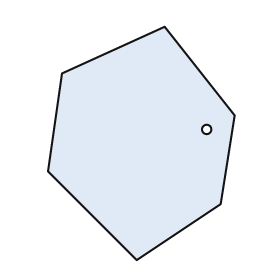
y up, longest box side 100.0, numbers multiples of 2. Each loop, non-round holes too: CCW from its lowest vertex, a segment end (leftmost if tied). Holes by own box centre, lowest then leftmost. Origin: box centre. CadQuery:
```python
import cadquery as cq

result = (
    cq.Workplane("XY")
    .moveTo(-2.0, -50.0)
    .lineTo(34.0, -26.0)
    .lineTo(40.0, 12.0)
    .lineTo(10.0, 50.0)
    .lineTo(-34.0, 30.0)
    .lineTo(-40.0, -12.0)
    .close()
    .moveTo(28.0, 6.0)
    .circle(2.0)
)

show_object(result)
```